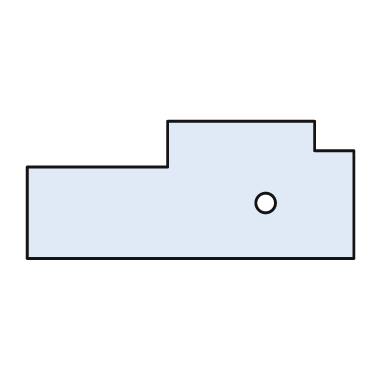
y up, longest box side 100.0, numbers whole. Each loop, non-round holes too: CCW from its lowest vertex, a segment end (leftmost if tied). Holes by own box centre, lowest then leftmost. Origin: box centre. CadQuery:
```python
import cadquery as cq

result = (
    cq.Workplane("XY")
    .moveTo(-50.0, -21.0)
    .lineTo(50.0, -21.0)
    .lineTo(50.0, 12.0)
    .lineTo(38.0, 12.0)
    .lineTo(38.0, 21.0)
    .lineTo(-7.0, 21.0)
    .lineTo(-7.0, 7.0)
    .lineTo(-50.0, 7.0)
    .close()
    .moveTo(23.0, -4.0)
    .circle(3.0)
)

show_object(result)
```